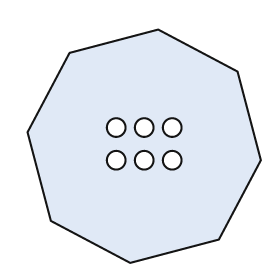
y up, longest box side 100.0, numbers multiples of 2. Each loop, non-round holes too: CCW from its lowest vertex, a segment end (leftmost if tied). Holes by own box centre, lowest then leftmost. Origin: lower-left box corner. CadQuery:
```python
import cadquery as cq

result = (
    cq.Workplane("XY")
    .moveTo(44.0, 0.0)
    .lineTo(82.0, 10.0)
    .lineTo(100.0, 44.0)
    .lineTo(90.0, 82.0)
    .lineTo(56.0, 100.0)
    .lineTo(18.0, 90.0)
    .lineTo(0.0, 56.0)
    .lineTo(10.0, 18.0)
    .close()
    .moveTo(38.0, 44.0)
    .circle(4.0)
    .moveTo(50.0, 44.0)
    .circle(4.0)
    .moveTo(62.0, 44.0)
    .circle(4.0)
    .moveTo(38.0, 58.0)
    .circle(4.0)
    .moveTo(50.0, 58.0)
    .circle(4.0)
    .moveTo(62.0, 58.0)
    .circle(4.0)
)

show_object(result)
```